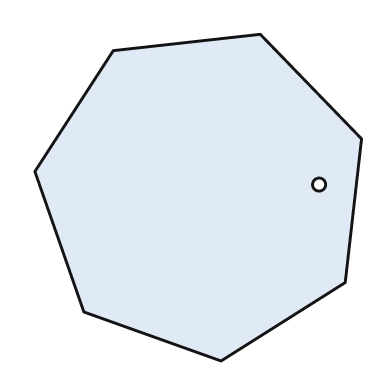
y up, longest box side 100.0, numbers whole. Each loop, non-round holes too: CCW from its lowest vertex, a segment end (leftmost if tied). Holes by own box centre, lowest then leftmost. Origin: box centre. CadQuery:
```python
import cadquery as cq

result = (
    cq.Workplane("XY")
    .moveTo(7.0, -50.0)
    .lineTo(45.0, -26.0)
    .lineTo(50.0, 18.0)
    .lineTo(19.0, 50.0)
    .lineTo(-26.0, 45.0)
    .lineTo(-50.0, 8.0)
    .lineTo(-35.0, -35.0)
    .close()
    .moveTo(37.0, 4.0)
    .circle(2.0)
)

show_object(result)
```